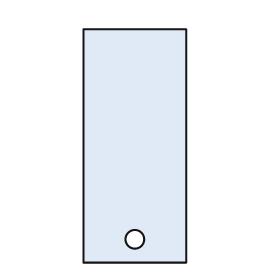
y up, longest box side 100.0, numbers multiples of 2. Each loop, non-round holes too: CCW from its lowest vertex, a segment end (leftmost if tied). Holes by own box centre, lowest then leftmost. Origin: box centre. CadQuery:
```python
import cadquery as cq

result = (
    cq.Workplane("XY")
    .moveTo(-22.0, -50.0)
    .lineTo(22.0, -50.0)
    .lineTo(22.0, 50.0)
    .lineTo(-22.0, 50.0)
    .close()
    .moveTo(0.0, -40.0)
    .circle(4.0)
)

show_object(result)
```